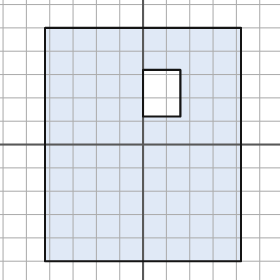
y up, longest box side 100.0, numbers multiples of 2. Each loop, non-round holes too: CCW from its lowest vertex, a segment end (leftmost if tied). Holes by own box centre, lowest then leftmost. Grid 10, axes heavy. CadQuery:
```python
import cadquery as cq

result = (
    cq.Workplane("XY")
    .moveTo(-42.0, -50.0)
    .lineTo(42.0, -50.0)
    .lineTo(42.0, 50.0)
    .lineTo(-42.0, 50.0)
    .close()
    .moveTo(0.0, 12.0)
    .lineTo(16.0, 12.0)
    .lineTo(16.0, 32.0)
    .lineTo(0.0, 32.0)
    .close()
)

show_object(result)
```